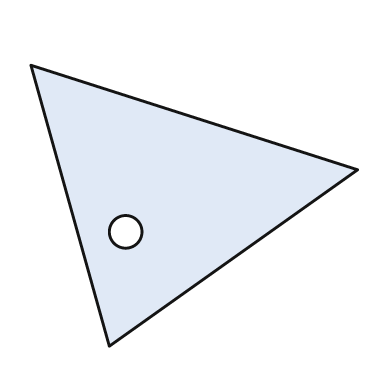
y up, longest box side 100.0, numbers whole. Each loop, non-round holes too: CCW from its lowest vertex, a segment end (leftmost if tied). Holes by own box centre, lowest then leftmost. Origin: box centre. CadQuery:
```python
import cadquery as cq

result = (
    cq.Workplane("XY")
    .moveTo(-26.0, -43.0)
    .lineTo(50.0, 11.0)
    .lineTo(-50.0, 43.0)
    .close()
    .moveTo(-21.0, -8.0)
    .circle(5.0)
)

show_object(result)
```